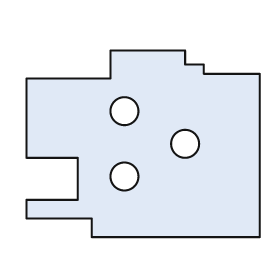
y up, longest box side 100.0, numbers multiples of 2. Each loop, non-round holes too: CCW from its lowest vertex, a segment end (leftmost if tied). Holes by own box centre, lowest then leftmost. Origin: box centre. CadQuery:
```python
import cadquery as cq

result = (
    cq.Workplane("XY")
    .moveTo(-22.0, -40.0)
    .lineTo(50.0, -40.0)
    .lineTo(50.0, 30.0)
    .lineTo(26.0, 30.0)
    .lineTo(26.0, 34.0)
    .lineTo(18.0, 34.0)
    .lineTo(18.0, 40.0)
    .lineTo(-14.0, 40.0)
    .lineTo(-14.0, 28.0)
    .lineTo(-50.0, 28.0)
    .lineTo(-50.0, -6.0)
    .lineTo(-28.0, -6.0)
    .lineTo(-28.0, -24.0)
    .lineTo(-50.0, -24.0)
    .lineTo(-50.0, -32.0)
    .lineTo(-22.0, -32.0)
    .close()
    .moveTo(-8.0, -14.0)
    .circle(6.0)
    .moveTo(18.0, 0.0)
    .circle(6.0)
    .moveTo(-8.0, 14.0)
    .circle(6.0)
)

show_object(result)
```